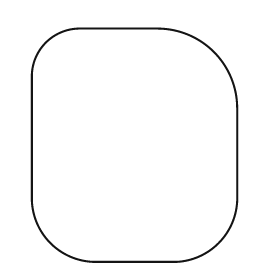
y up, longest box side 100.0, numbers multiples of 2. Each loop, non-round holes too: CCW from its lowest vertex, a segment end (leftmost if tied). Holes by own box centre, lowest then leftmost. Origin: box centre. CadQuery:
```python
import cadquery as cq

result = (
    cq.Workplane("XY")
    .moveTo(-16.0, -50.0)
    .lineTo(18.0, -50.0)
    .threePointArc((36.0, -42.0), (44.0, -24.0))
    .lineTo(44.0, 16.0)
    .threePointArc((34.0, 40.0), (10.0, 50.0))
    .lineTo(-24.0, 50.0)
    .threePointArc((-38.0, 44.0), (-44.0, 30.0))
    .lineTo(-44.0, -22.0)
    .threePointArc((-36.0, -42.0), (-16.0, -50.0))
    .close()
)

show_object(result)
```